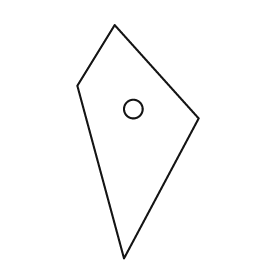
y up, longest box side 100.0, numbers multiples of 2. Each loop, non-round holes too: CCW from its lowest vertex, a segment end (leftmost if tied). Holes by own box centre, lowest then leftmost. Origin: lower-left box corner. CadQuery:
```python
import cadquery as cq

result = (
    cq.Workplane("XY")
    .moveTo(20.0, 0.0)
    .lineTo(52.0, 60.0)
    .lineTo(16.0, 100.0)
    .lineTo(0.0, 74.0)
    .close()
    .moveTo(24.0, 64.0)
    .circle(4.0)
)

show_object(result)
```